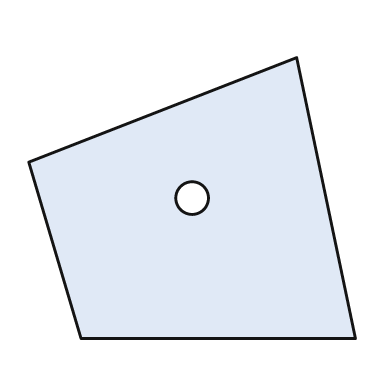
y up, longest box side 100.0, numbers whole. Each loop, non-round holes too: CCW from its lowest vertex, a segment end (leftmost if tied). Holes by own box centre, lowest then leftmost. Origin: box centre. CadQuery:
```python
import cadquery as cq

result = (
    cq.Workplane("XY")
    .moveTo(-34.0, -43.0)
    .lineTo(50.0, -43.0)
    .lineTo(32.0, 43.0)
    .lineTo(-50.0, 11.0)
    .close()
    .moveTo(0.0, 0.0)
    .circle(5.0)
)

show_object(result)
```